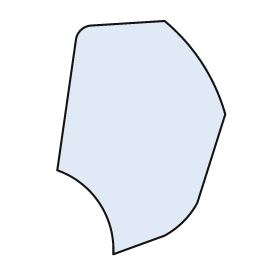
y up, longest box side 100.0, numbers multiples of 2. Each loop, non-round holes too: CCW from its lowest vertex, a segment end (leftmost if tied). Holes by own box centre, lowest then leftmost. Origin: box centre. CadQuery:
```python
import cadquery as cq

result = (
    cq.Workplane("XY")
    .moveTo(-12.0, -50.0)
    .lineTo(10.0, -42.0)
    .threePointArc((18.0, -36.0), (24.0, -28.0))
    .lineTo(36.0, 10.0)
    .threePointArc((26.0, 32.0), (10.0, 50.0))
    .lineTo(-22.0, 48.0)
    .threePointArc((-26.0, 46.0), (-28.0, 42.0))
    .lineTo(-36.0, -14.0)
    .threePointArc((-18.0, -28.0), (-12.0, -50.0))
    .close()
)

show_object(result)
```